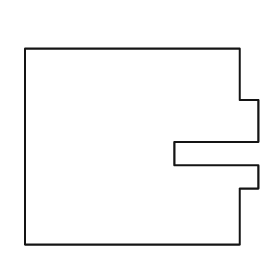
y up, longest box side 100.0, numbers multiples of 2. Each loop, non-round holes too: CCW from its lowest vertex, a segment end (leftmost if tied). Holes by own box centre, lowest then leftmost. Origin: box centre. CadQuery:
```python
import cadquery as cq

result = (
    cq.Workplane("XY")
    .moveTo(-50.0, -42.0)
    .lineTo(42.0, -42.0)
    .lineTo(42.0, -18.0)
    .lineTo(50.0, -18.0)
    .lineTo(50.0, -8.0)
    .lineTo(14.0, -8.0)
    .lineTo(14.0, 2.0)
    .lineTo(50.0, 2.0)
    .lineTo(50.0, 20.0)
    .lineTo(42.0, 20.0)
    .lineTo(42.0, 42.0)
    .lineTo(-50.0, 42.0)
    .close()
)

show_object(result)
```